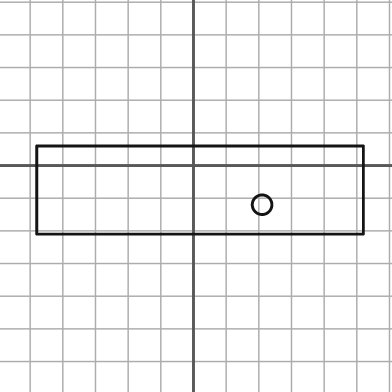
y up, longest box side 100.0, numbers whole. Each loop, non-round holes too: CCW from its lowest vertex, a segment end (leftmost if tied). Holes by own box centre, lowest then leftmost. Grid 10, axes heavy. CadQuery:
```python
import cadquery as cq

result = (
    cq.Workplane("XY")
    .moveTo(-48.0, -21.0)
    .lineTo(52.0, -21.0)
    .lineTo(52.0, 6.0)
    .lineTo(-48.0, 6.0)
    .close()
    .moveTo(21.0, -12.0)
    .circle(3.0)
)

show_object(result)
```